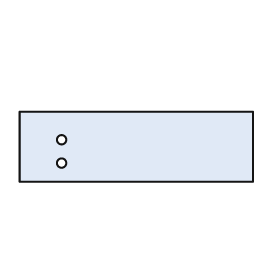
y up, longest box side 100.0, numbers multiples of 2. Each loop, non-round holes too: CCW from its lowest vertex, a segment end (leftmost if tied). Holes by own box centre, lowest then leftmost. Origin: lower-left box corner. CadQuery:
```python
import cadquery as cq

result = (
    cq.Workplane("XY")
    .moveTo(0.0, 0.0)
    .lineTo(100.0, 0.0)
    .lineTo(100.0, 30.0)
    .lineTo(0.0, 30.0)
    .close()
    .moveTo(18.0, 8.0)
    .circle(2.0)
    .moveTo(18.0, 18.0)
    .circle(2.0)
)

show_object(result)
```